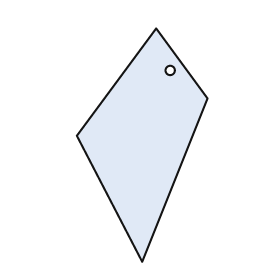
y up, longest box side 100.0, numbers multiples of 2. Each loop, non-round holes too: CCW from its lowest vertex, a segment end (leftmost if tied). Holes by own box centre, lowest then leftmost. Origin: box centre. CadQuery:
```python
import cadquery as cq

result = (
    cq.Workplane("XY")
    .moveTo(0.0, -50.0)
    .lineTo(28.0, 20.0)
    .lineTo(6.0, 50.0)
    .lineTo(-28.0, 4.0)
    .close()
    .moveTo(12.0, 32.0)
    .circle(2.0)
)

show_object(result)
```